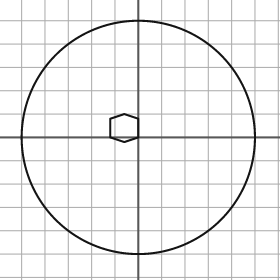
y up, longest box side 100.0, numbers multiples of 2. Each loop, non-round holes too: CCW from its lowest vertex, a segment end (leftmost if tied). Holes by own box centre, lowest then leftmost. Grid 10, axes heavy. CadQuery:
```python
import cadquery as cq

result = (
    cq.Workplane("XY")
    .moveTo(0.0, 0.0)
    .circle(50.0)
    .moveTo(-6.0, -2.0)
    .lineTo(0.0, 0.0)
    .lineTo(0.0, 8.0)
    .lineTo(-6.0, 10.0)
    .lineTo(-12.0, 8.0)
    .lineTo(-12.0, 0.0)
    .close()
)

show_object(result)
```